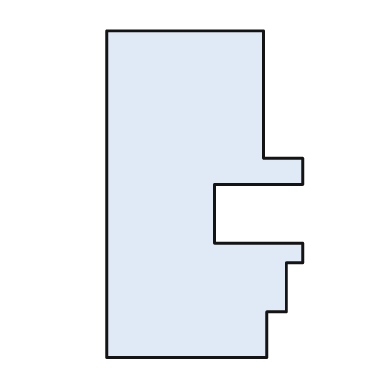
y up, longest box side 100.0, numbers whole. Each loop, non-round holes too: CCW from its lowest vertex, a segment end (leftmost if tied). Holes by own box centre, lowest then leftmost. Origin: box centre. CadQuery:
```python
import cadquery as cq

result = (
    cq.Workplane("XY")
    .moveTo(-30.0, -50.0)
    .lineTo(19.0, -50.0)
    .lineTo(19.0, -36.0)
    .lineTo(25.0, -36.0)
    .lineTo(25.0, -21.0)
    .lineTo(30.0, -21.0)
    .lineTo(30.0, -15.0)
    .lineTo(3.0, -15.0)
    .lineTo(3.0, 3.0)
    .lineTo(30.0, 3.0)
    .lineTo(30.0, 11.0)
    .lineTo(18.0, 11.0)
    .lineTo(18.0, 50.0)
    .lineTo(-30.0, 50.0)
    .close()
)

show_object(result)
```